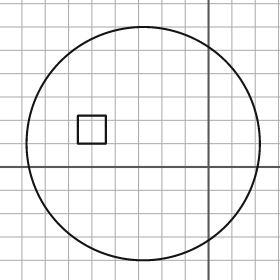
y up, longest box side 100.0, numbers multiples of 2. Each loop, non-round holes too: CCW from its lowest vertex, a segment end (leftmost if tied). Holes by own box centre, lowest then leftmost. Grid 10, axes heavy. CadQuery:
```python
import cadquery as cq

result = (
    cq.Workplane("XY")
    .moveTo(-28.0, 10.0)
    .circle(50.0)
    .moveTo(-56.0, 10.0)
    .lineTo(-44.0, 10.0)
    .lineTo(-44.0, 22.0)
    .lineTo(-56.0, 22.0)
    .close()
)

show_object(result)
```